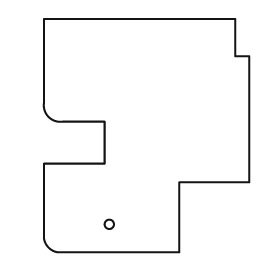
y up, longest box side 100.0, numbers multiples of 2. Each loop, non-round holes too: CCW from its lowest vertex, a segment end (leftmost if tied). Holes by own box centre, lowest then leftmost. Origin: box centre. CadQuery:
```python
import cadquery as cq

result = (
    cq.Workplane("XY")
    .moveTo(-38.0, -50.0)
    .lineTo(14.0, -50.0)
    .lineTo(14.0, -20.0)
    .lineTo(44.0, -20.0)
    .lineTo(44.0, 34.0)
    .lineTo(38.0, 34.0)
    .lineTo(38.0, 50.0)
    .lineTo(-44.0, 50.0)
    .lineTo(-44.0, 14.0)
    .threePointArc((-42.0, 8.0), (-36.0, 6.0))
    .lineTo(-18.0, 6.0)
    .lineTo(-18.0, -12.0)
    .lineTo(-44.0, -12.0)
    .lineTo(-44.0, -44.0)
    .threePointArc((-42.0, -48.0), (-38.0, -50.0))
    .close()
    .moveTo(-16.0, -38.0)
    .circle(2.0)
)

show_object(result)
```